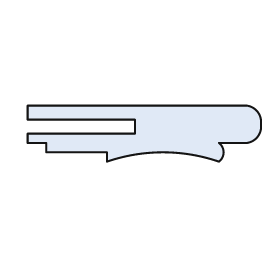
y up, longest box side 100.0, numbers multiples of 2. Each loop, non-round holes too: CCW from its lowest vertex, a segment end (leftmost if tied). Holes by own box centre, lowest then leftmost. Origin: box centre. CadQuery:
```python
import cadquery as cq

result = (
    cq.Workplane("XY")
    .moveTo(-16.0, -12.0)
    .threePointArc((8.0, -8.0), (32.0, -12.0))
    .threePointArc((34.0, -8.0), (32.0, -4.0))
    .lineTo(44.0, -4.0)
    .threePointArc((48.0, -2.0), (50.0, 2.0))
    .lineTo(50.0, 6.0)
    .threePointArc((48.0, 10.0), (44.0, 12.0))
    .lineTo(-50.0, 12.0)
    .lineTo(-50.0, 6.0)
    .lineTo(-4.0, 6.0)
    .lineTo(-4.0, 0.0)
    .lineTo(-50.0, 0.0)
    .lineTo(-50.0, -4.0)
    .lineTo(-42.0, -4.0)
    .lineTo(-42.0, -8.0)
    .lineTo(-16.0, -8.0)
    .close()
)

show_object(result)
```